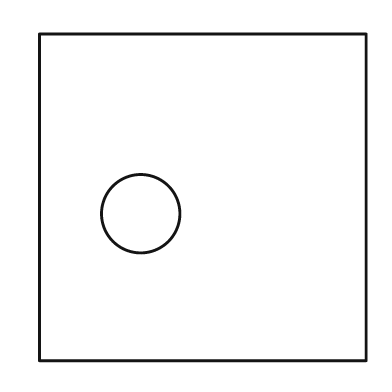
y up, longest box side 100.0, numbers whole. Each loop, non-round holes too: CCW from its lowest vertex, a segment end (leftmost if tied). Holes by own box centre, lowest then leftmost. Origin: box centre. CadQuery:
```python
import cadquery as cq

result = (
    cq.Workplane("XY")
    .moveTo(-50.0, -50.0)
    .lineTo(50.0, -50.0)
    .lineTo(50.0, 50.0)
    .lineTo(-50.0, 50.0)
    .close()
    .moveTo(-19.0, -5.0)
    .circle(12.0)
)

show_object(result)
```